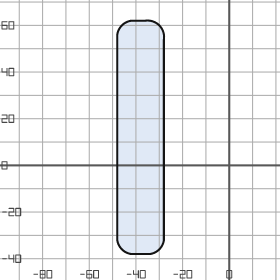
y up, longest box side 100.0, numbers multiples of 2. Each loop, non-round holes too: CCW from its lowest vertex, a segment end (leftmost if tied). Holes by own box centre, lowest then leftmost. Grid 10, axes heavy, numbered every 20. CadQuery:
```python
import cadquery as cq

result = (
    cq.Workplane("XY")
    .moveTo(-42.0, -38.0)
    .lineTo(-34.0, -38.0)
    .threePointArc((-30.0, -36.0), (-28.0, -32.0))
    .lineTo(-28.0, 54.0)
    .threePointArc((-30.0, 60.0), (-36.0, 62.0))
    .lineTo(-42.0, 62.0)
    .threePointArc((-46.0, 60.0), (-48.0, 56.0))
    .lineTo(-48.0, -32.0)
    .threePointArc((-46.0, -36.0), (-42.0, -38.0))
    .close()
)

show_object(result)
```